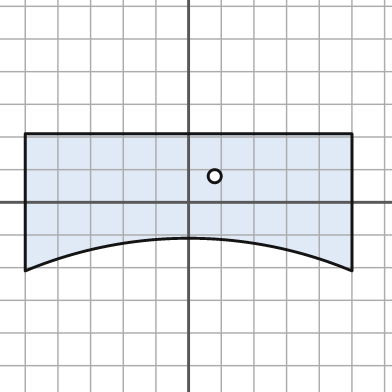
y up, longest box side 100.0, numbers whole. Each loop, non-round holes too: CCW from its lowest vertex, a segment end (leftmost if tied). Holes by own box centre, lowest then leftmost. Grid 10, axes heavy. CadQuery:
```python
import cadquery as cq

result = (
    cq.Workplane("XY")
    .moveTo(-50.0, -21.0)
    .threePointArc((0.0, -11.0), (50.0, -21.0))
    .lineTo(50.0, 21.0)
    .lineTo(-50.0, 21.0)
    .close()
    .moveTo(8.0, 8.0)
    .circle(2.0)
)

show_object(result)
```